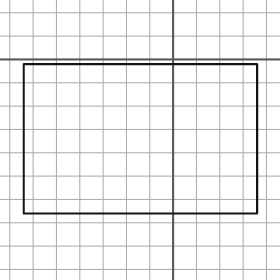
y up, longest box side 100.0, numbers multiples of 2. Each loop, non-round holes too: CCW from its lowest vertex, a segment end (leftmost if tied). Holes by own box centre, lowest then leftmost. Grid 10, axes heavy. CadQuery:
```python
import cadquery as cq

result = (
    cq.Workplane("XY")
    .moveTo(-64.0, -66.0)
    .lineTo(36.0, -66.0)
    .lineTo(36.0, -2.0)
    .lineTo(-64.0, -2.0)
    .close()
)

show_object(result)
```